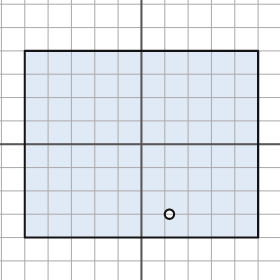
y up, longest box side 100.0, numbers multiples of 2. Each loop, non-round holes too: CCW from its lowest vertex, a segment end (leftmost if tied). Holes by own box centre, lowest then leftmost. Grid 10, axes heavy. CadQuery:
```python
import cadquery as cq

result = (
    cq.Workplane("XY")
    .moveTo(-50.0, -40.0)
    .lineTo(50.0, -40.0)
    .lineTo(50.0, 40.0)
    .lineTo(-50.0, 40.0)
    .close()
    .moveTo(12.0, -30.0)
    .circle(2.0)
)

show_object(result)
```